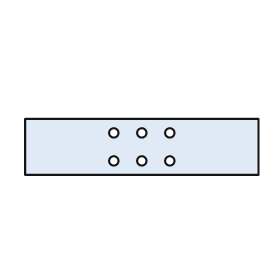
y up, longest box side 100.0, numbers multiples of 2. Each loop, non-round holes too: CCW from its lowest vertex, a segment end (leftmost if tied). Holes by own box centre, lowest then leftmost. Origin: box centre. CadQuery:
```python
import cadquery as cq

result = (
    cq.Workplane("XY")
    .moveTo(-50.0, -12.0)
    .lineTo(50.0, -12.0)
    .lineTo(50.0, 12.0)
    .lineTo(-50.0, 12.0)
    .close()
    .moveTo(-12.0, -6.0)
    .circle(2.0)
    .moveTo(0.0, -6.0)
    .circle(2.0)
    .moveTo(12.0, -6.0)
    .circle(2.0)
    .moveTo(-12.0, 6.0)
    .circle(2.0)
    .moveTo(0.0, 6.0)
    .circle(2.0)
    .moveTo(12.0, 6.0)
    .circle(2.0)
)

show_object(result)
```